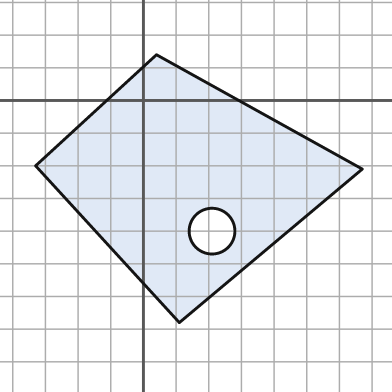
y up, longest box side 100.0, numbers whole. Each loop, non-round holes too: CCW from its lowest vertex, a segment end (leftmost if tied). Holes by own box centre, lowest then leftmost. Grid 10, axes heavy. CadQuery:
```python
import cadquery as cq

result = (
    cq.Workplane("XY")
    .moveTo(11.0, -68.0)
    .lineTo(67.0, -21.0)
    .lineTo(4.0, 14.0)
    .lineTo(-33.0, -20.0)
    .close()
    .moveTo(21.0, -40.0)
    .circle(7.0)
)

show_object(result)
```